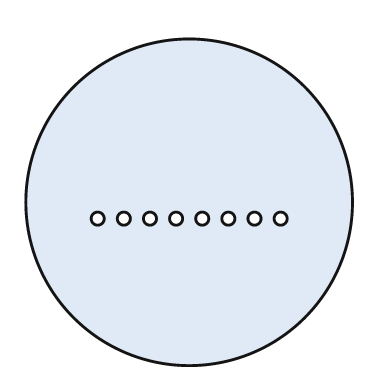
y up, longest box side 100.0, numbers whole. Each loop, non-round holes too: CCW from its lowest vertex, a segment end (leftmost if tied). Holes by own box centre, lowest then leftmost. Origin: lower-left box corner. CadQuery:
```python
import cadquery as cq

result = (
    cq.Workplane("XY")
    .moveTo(50.0, 50.0)
    .circle(50.0)
    .moveTo(22.0, 45.0)
    .circle(2.0)
    .moveTo(30.0, 45.0)
    .circle(2.0)
    .moveTo(38.0, 45.0)
    .circle(2.0)
    .moveTo(46.0, 45.0)
    .circle(2.0)
    .moveTo(54.0, 45.0)
    .circle(2.0)
    .moveTo(62.0, 45.0)
    .circle(2.0)
    .moveTo(70.0, 45.0)
    .circle(2.0)
    .moveTo(78.0, 45.0)
    .circle(2.0)
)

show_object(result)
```